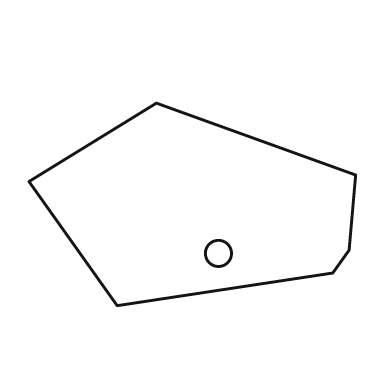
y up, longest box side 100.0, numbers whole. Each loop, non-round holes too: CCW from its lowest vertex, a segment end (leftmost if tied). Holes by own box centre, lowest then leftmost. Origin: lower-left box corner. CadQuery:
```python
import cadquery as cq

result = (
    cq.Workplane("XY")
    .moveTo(27.0, 0.0)
    .lineTo(93.0, 10.0)
    .lineTo(98.0, 17.0)
    .lineTo(100.0, 40.0)
    .lineTo(39.0, 62.0)
    .lineTo(0.0, 38.0)
    .close()
    .moveTo(58.0, 16.0)
    .circle(4.0)
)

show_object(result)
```